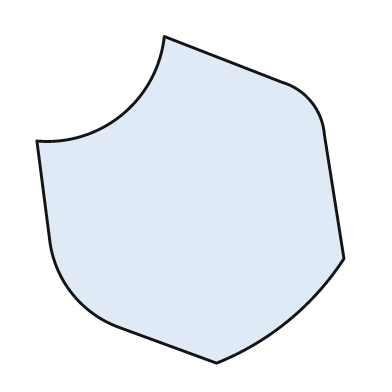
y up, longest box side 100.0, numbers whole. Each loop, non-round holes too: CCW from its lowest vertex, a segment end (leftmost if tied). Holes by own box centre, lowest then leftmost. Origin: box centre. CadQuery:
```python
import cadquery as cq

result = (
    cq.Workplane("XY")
    .moveTo(8.0, -50.0)
    .threePointArc((30.0, -37.0), (47.0, -18.0))
    .lineTo(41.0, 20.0)
    .threePointArc((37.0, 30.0), (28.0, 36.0))
    .lineTo(-8.0, 50.0)
    .threePointArc((-21.0, 26.0), (-47.0, 18.0))
    .lineTo(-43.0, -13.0)
    .threePointArc((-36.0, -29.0), (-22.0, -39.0))
    .close()
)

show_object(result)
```